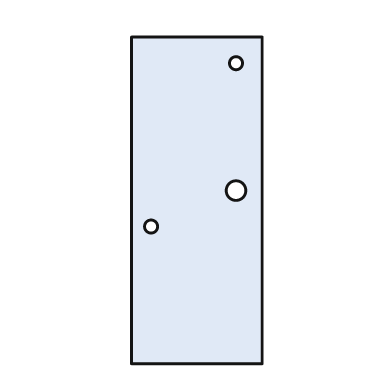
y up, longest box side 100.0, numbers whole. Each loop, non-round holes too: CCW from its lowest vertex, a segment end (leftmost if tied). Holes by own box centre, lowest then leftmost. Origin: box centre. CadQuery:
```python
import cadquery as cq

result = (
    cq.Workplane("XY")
    .moveTo(-20.0, -50.0)
    .lineTo(20.0, -50.0)
    .lineTo(20.0, 50.0)
    .lineTo(-20.0, 50.0)
    .close()
    .moveTo(-14.0, -8.0)
    .circle(2.0)
    .moveTo(12.0, 3.0)
    .circle(3.0)
    .moveTo(12.0, 42.0)
    .circle(2.0)
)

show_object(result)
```